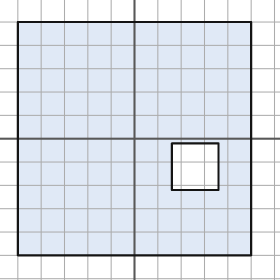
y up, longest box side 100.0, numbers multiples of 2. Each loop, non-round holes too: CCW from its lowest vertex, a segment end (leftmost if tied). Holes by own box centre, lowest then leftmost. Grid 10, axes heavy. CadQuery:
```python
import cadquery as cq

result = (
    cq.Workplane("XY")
    .moveTo(-50.0, -50.0)
    .lineTo(50.0, -50.0)
    .lineTo(50.0, 50.0)
    .lineTo(-50.0, 50.0)
    .close()
    .moveTo(16.0, -22.0)
    .lineTo(36.0, -22.0)
    .lineTo(36.0, -2.0)
    .lineTo(16.0, -2.0)
    .close()
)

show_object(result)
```